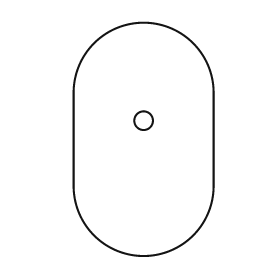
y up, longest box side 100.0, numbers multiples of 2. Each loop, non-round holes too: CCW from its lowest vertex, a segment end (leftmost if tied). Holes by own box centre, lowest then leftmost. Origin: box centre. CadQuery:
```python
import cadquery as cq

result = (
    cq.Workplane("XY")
    .moveTo(-30.0, -20.0)
    .threePointArc((0.0, -50.0), (30.0, -20.0))
    .lineTo(30.0, 20.0)
    .threePointArc((0.0, 50.0), (-30.0, 20.0))
    .close()
    .moveTo(0.0, 8.0)
    .circle(4.0)
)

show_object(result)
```